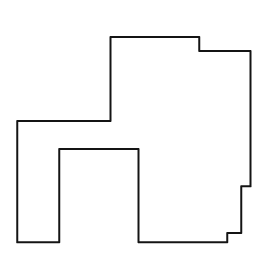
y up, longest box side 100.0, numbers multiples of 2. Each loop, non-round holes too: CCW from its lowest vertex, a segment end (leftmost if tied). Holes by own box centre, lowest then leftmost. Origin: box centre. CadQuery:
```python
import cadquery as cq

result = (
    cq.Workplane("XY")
    .moveTo(-50.0, -44.0)
    .lineTo(-32.0, -44.0)
    .lineTo(-32.0, -4.0)
    .lineTo(2.0, -4.0)
    .lineTo(2.0, -44.0)
    .lineTo(40.0, -44.0)
    .lineTo(40.0, -40.0)
    .lineTo(46.0, -40.0)
    .lineTo(46.0, -20.0)
    .lineTo(50.0, -20.0)
    .lineTo(50.0, 38.0)
    .lineTo(28.0, 38.0)
    .lineTo(28.0, 44.0)
    .lineTo(-10.0, 44.0)
    .lineTo(-10.0, 8.0)
    .lineTo(-50.0, 8.0)
    .close()
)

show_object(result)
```